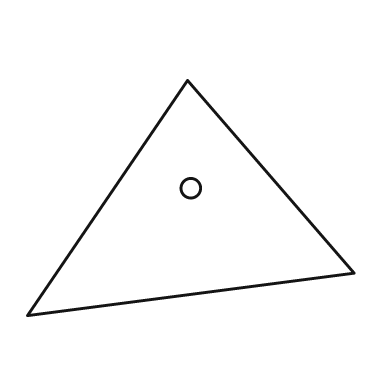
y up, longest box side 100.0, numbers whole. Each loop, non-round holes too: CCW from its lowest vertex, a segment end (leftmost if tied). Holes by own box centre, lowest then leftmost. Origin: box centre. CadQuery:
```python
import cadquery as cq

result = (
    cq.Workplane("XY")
    .moveTo(-50.0, -36.0)
    .lineTo(50.0, -23.0)
    .lineTo(-1.0, 36.0)
    .close()
    .moveTo(0.0, 3.0)
    .circle(3.0)
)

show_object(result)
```